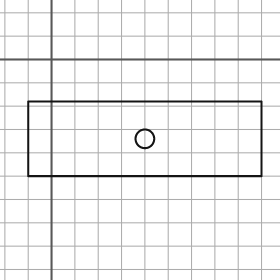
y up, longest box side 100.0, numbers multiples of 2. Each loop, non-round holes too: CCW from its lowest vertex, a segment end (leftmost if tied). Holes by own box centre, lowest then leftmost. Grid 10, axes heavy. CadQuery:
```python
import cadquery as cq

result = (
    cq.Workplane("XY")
    .moveTo(-10.0, -50.0)
    .lineTo(90.0, -50.0)
    .lineTo(90.0, -18.0)
    .lineTo(-10.0, -18.0)
    .close()
    .moveTo(40.0, -34.0)
    .circle(4.0)
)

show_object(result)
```